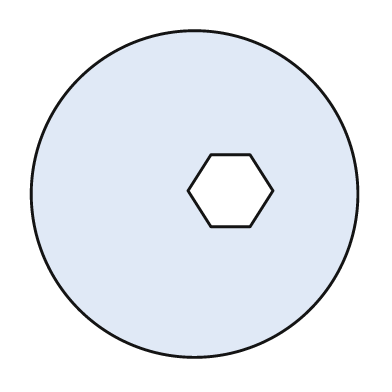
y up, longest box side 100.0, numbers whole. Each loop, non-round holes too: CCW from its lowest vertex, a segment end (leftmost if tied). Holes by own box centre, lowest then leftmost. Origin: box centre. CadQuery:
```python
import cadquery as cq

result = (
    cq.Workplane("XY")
    .moveTo(0.0, 0.0)
    .circle(50.0)
    .moveTo(5.0, -10.0)
    .lineTo(17.0, -10.0)
    .lineTo(24.0, 1.0)
    .lineTo(17.0, 12.0)
    .lineTo(5.0, 12.0)
    .lineTo(-2.0, 1.0)
    .close()
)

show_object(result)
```